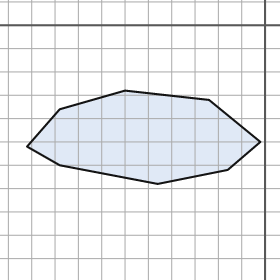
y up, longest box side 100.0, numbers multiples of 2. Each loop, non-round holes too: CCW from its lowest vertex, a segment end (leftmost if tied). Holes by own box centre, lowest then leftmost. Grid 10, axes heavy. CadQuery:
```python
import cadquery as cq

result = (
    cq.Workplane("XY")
    .moveTo(-46.0, -68.0)
    .lineTo(-16.0, -62.0)
    .lineTo(-2.0, -50.0)
    .lineTo(-24.0, -32.0)
    .lineTo(-60.0, -28.0)
    .lineTo(-88.0, -36.0)
    .lineTo(-102.0, -52.0)
    .lineTo(-88.0, -60.0)
    .close()
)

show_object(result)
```